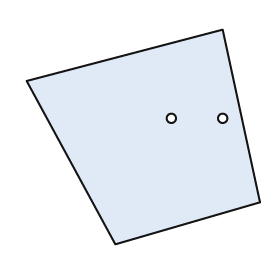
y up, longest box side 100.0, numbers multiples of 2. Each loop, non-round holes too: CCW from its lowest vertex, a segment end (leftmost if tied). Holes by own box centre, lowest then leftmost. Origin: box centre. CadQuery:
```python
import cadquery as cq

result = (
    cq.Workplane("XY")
    .moveTo(-12.0, -46.0)
    .lineTo(50.0, -28.0)
    .lineTo(34.0, 46.0)
    .lineTo(-50.0, 24.0)
    .close()
    .moveTo(12.0, 8.0)
    .circle(2.0)
    .moveTo(34.0, 8.0)
    .circle(2.0)
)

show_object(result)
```